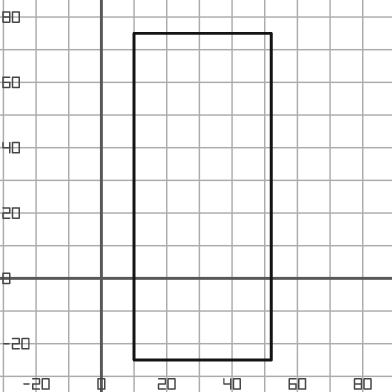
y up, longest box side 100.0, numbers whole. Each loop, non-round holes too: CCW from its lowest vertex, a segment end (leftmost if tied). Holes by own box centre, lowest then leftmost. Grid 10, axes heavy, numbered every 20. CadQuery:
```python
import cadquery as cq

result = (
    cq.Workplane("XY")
    .moveTo(10.0, -25.0)
    .lineTo(52.0, -25.0)
    .lineTo(52.0, 75.0)
    .lineTo(10.0, 75.0)
    .close()
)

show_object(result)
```